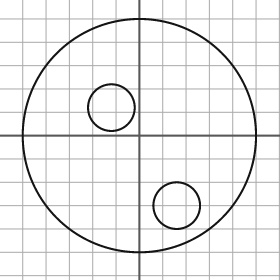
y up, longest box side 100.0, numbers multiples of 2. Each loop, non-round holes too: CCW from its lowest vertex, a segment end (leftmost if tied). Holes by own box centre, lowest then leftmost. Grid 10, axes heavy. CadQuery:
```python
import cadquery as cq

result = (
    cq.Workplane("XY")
    .moveTo(0.0, 0.0)
    .circle(50.0)
    .moveTo(16.0, -30.0)
    .circle(10.0)
    .moveTo(-12.0, 12.0)
    .circle(10.0)
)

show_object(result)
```